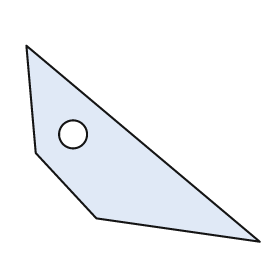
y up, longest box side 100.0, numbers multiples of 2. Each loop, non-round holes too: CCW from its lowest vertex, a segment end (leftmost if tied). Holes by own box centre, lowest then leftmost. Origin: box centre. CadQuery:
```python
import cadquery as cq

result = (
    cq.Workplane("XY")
    .moveTo(50.0, -42.0)
    .lineTo(-50.0, 42.0)
    .lineTo(-46.0, -4.0)
    .lineTo(-20.0, -32.0)
    .close()
    .moveTo(-30.0, 4.0)
    .circle(6.0)
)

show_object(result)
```